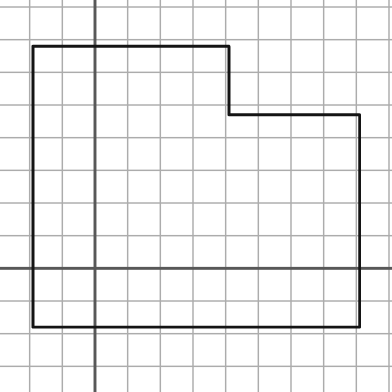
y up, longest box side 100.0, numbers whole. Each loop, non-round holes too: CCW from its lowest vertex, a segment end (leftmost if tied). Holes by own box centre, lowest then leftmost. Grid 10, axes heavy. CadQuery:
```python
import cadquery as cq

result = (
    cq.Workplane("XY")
    .moveTo(-19.0, -18.0)
    .lineTo(81.0, -18.0)
    .lineTo(81.0, 47.0)
    .lineTo(41.0, 47.0)
    .lineTo(41.0, 68.0)
    .lineTo(-19.0, 68.0)
    .close()
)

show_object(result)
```